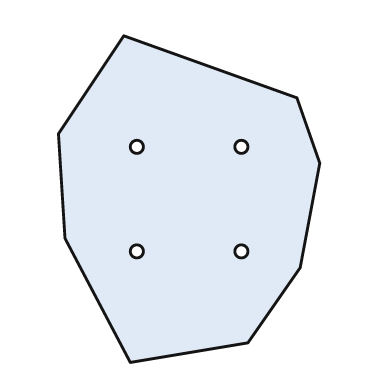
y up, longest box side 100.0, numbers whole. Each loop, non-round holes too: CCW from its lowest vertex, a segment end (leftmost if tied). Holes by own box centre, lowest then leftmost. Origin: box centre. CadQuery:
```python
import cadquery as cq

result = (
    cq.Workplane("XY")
    .moveTo(-18.0, -50.0)
    .lineTo(18.0, -44.0)
    .lineTo(34.0, -21.0)
    .lineTo(40.0, 11.0)
    .lineTo(33.0, 31.0)
    .lineTo(-20.0, 50.0)
    .lineTo(-40.0, 20.0)
    .lineTo(-38.0, -12.0)
    .close()
    .moveTo(-16.0, -16.0)
    .circle(2.0)
    .moveTo(16.0, -16.0)
    .circle(2.0)
    .moveTo(-16.0, 16.0)
    .circle(2.0)
    .moveTo(16.0, 16.0)
    .circle(2.0)
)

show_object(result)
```